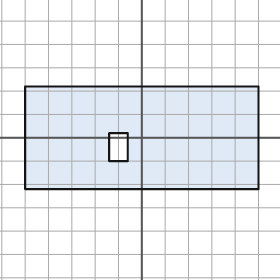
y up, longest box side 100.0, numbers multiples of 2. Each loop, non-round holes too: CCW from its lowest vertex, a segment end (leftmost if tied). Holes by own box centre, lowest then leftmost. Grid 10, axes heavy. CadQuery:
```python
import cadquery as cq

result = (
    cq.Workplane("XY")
    .moveTo(-50.0, -22.0)
    .lineTo(50.0, -22.0)
    .lineTo(50.0, 22.0)
    .lineTo(-50.0, 22.0)
    .close()
    .moveTo(-14.0, -10.0)
    .lineTo(-6.0, -10.0)
    .lineTo(-6.0, 2.0)
    .lineTo(-14.0, 2.0)
    .close()
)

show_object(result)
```